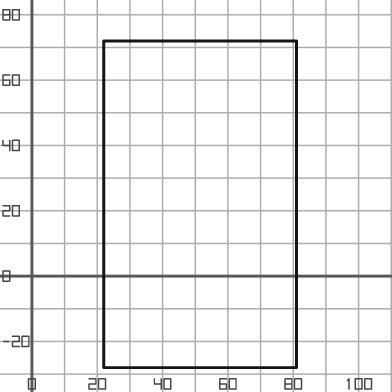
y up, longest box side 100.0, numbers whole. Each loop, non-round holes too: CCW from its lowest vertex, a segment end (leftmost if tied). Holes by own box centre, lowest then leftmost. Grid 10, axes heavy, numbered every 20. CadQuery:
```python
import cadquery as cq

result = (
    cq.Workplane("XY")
    .moveTo(22.0, -28.0)
    .lineTo(81.0, -28.0)
    .lineTo(81.0, 72.0)
    .lineTo(22.0, 72.0)
    .close()
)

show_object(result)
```